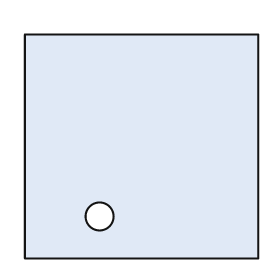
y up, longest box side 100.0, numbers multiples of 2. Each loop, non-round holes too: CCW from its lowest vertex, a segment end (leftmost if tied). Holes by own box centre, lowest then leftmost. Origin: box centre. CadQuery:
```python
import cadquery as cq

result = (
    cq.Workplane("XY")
    .moveTo(-50.0, -48.0)
    .lineTo(50.0, -48.0)
    .lineTo(50.0, 48.0)
    .lineTo(-50.0, 48.0)
    .close()
    .moveTo(-18.0, -30.0)
    .circle(6.0)
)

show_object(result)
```